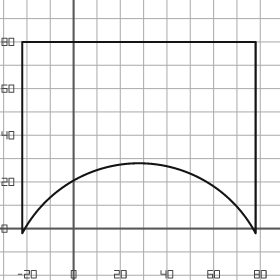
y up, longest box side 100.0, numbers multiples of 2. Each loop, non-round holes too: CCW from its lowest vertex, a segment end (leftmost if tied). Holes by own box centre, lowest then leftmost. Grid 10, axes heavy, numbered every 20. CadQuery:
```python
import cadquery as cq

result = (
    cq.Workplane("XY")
    .moveTo(-22.0, -2.0)
    .threePointArc((28.0, 28.0), (78.0, -2.0))
    .lineTo(78.0, 80.0)
    .lineTo(-22.0, 80.0)
    .close()
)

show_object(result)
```